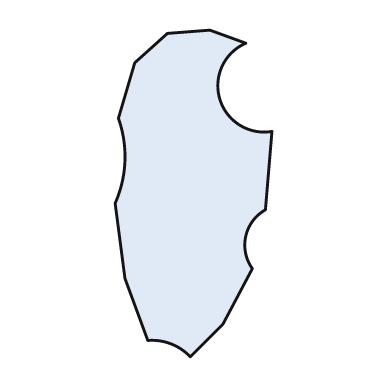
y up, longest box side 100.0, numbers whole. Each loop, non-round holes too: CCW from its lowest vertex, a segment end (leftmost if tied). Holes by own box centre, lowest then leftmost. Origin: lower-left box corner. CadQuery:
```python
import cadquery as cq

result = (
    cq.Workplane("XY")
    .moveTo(23.0, 0.0)
    .lineTo(33.0, 10.0)
    .lineTo(42.0, 27.0)
    .threePointArc((40.0, 37.0), (46.0, 45.0))
    .lineTo(48.0, 69.0)
    .threePointArc((32.0, 79.0), (40.0, 96.0))
    .lineTo(29.0, 100.0)
    .lineTo(16.0, 99.0)
    .lineTo(6.0, 90.0)
    .lineTo(1.0, 73.0)
    .threePointArc((3.0, 60.0), (0.0, 47.0))
    .lineTo(3.0, 24.0)
    .lineTo(10.0, 5.0)
    .threePointArc((17.0, 4.0), (23.0, 0.0))
    .close()
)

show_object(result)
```